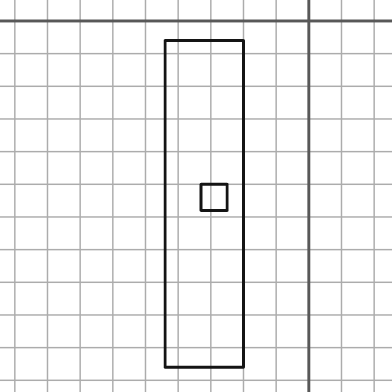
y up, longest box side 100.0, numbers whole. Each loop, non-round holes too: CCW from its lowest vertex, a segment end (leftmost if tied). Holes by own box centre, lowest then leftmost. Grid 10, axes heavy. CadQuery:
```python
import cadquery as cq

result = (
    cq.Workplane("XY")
    .moveTo(-44.0, -106.0)
    .lineTo(-20.0, -106.0)
    .lineTo(-20.0, -6.0)
    .lineTo(-44.0, -6.0)
    .close()
    .moveTo(-33.0, -58.0)
    .lineTo(-25.0, -58.0)
    .lineTo(-25.0, -50.0)
    .lineTo(-33.0, -50.0)
    .close()
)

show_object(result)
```